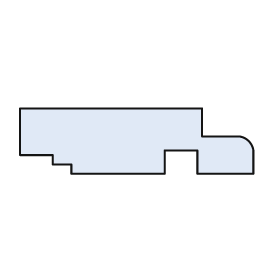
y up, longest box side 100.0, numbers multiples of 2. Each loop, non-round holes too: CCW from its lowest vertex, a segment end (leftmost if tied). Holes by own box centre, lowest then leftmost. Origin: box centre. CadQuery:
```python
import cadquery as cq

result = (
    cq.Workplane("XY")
    .moveTo(-28.0, -14.0)
    .lineTo(12.0, -14.0)
    .lineTo(12.0, -4.0)
    .lineTo(26.0, -4.0)
    .lineTo(26.0, -14.0)
    .lineTo(50.0, -14.0)
    .lineTo(50.0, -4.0)
    .threePointArc((48.0, 0.0), (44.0, 2.0))
    .lineTo(28.0, 2.0)
    .lineTo(28.0, 14.0)
    .lineTo(-50.0, 14.0)
    .lineTo(-50.0, -6.0)
    .lineTo(-36.0, -6.0)
    .lineTo(-36.0, -10.0)
    .lineTo(-28.0, -10.0)
    .close()
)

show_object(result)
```